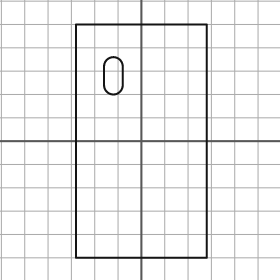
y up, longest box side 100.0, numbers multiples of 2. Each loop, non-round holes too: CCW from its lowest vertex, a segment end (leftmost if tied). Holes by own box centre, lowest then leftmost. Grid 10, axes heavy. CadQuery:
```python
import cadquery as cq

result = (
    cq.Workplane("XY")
    .moveTo(-28.0, -50.0)
    .lineTo(28.0, -50.0)
    .lineTo(28.0, 50.0)
    .lineTo(-28.0, 50.0)
    .close()
    .moveTo(-16.0, 24.0)
    .threePointArc((-12.0, 20.0), (-8.0, 24.0))
    .lineTo(-8.0, 32.0)
    .threePointArc((-12.0, 36.0), (-16.0, 32.0))
    .close()
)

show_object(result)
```